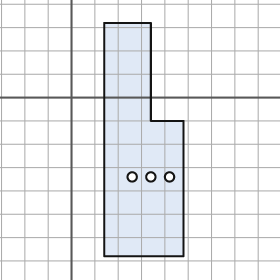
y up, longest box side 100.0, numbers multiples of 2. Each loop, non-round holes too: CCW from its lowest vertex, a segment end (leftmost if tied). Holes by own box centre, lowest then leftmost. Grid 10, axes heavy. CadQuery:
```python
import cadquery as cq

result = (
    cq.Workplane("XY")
    .moveTo(14.0, -68.0)
    .lineTo(48.0, -68.0)
    .lineTo(48.0, -10.0)
    .lineTo(34.0, -10.0)
    .lineTo(34.0, 32.0)
    .lineTo(14.0, 32.0)
    .close()
    .moveTo(26.0, -34.0)
    .circle(2.0)
    .moveTo(34.0, -34.0)
    .circle(2.0)
    .moveTo(42.0, -34.0)
    .circle(2.0)
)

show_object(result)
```